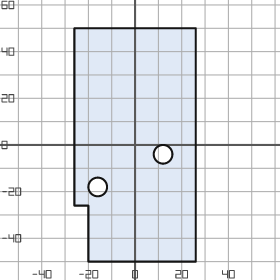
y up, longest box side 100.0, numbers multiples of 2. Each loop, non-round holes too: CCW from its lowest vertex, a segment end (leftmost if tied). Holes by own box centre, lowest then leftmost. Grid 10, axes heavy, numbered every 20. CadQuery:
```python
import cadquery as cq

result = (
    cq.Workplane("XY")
    .moveTo(-20.0, -50.0)
    .lineTo(26.0, -50.0)
    .lineTo(26.0, 50.0)
    .lineTo(-26.0, 50.0)
    .lineTo(-26.0, -26.0)
    .lineTo(-20.0, -26.0)
    .close()
    .moveTo(-16.0, -18.0)
    .circle(4.0)
    .moveTo(12.0, -4.0)
    .circle(4.0)
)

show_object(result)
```